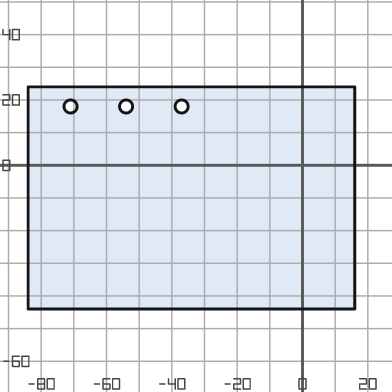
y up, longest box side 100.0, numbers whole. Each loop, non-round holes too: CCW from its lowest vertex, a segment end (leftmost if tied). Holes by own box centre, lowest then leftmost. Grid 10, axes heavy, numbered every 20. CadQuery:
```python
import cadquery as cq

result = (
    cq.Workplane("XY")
    .moveTo(-84.0, -44.0)
    .lineTo(16.0, -44.0)
    .lineTo(16.0, 24.0)
    .lineTo(-84.0, 24.0)
    .close()
    .moveTo(-71.0, 18.0)
    .circle(2.0)
    .moveTo(-54.0, 18.0)
    .circle(2.0)
    .moveTo(-37.0, 18.0)
    .circle(2.0)
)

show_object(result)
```